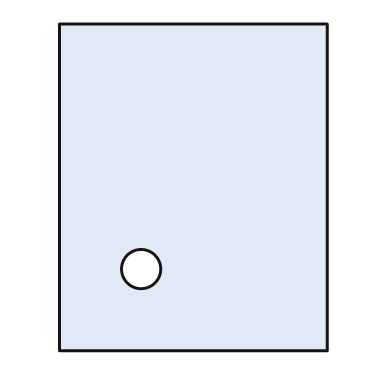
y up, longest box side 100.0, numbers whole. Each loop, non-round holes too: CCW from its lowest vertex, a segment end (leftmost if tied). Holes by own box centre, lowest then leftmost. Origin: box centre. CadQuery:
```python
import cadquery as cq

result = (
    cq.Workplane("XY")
    .moveTo(-41.0, -50.0)
    .lineTo(41.0, -50.0)
    .lineTo(41.0, 50.0)
    .lineTo(-41.0, 50.0)
    .close()
    .moveTo(-16.0, -25.0)
    .circle(6.0)
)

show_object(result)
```